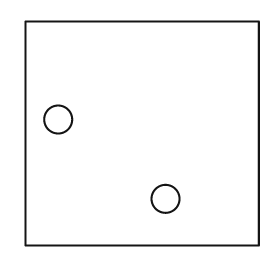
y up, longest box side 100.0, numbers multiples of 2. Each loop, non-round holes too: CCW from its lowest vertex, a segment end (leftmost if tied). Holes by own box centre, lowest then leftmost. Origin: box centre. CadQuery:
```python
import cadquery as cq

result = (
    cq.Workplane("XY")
    .moveTo(-50.0, -48.0)
    .lineTo(50.0, -48.0)
    .lineTo(50.0, 48.0)
    .lineTo(-50.0, 48.0)
    .close()
    .moveTo(10.0, -28.0)
    .circle(6.0)
    .moveTo(-36.0, 6.0)
    .circle(6.0)
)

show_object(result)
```